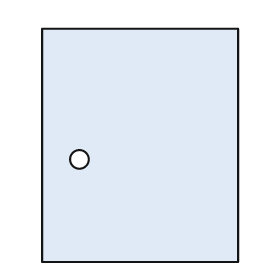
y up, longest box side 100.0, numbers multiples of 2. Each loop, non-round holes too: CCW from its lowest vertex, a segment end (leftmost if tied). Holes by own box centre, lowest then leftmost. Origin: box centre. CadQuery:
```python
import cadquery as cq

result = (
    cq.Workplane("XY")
    .moveTo(-42.0, -50.0)
    .lineTo(42.0, -50.0)
    .lineTo(42.0, 50.0)
    .lineTo(-42.0, 50.0)
    .close()
    .moveTo(-26.0, -6.0)
    .circle(4.0)
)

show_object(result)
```